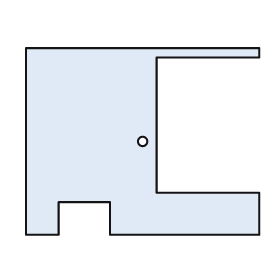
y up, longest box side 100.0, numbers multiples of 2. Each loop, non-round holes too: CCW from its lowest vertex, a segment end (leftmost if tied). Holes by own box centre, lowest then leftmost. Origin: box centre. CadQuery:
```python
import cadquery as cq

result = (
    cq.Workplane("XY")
    .moveTo(-50.0, -40.0)
    .lineTo(-36.0, -40.0)
    .lineTo(-36.0, -26.0)
    .lineTo(-14.0, -26.0)
    .lineTo(-14.0, -40.0)
    .lineTo(50.0, -40.0)
    .lineTo(50.0, -22.0)
    .lineTo(6.0, -22.0)
    .lineTo(6.0, 36.0)
    .lineTo(50.0, 36.0)
    .lineTo(50.0, 40.0)
    .lineTo(-50.0, 40.0)
    .close()
    .moveTo(0.0, 0.0)
    .circle(2.0)
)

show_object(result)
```